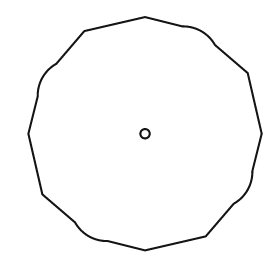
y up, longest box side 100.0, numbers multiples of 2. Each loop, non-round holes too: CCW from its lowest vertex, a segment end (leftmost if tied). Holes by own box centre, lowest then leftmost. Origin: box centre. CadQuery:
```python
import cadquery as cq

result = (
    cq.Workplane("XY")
    .moveTo(0.0, -50.0)
    .lineTo(26.0, -44.0)
    .lineTo(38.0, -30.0)
    .threePointArc((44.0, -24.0), (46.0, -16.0))
    .lineTo(50.0, 0.0)
    .lineTo(44.0, 26.0)
    .lineTo(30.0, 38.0)
    .threePointArc((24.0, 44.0), (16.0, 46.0))
    .lineTo(0.0, 50.0)
    .lineTo(-26.0, 44.0)
    .lineTo(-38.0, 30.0)
    .threePointArc((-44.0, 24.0), (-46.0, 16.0))
    .lineTo(-50.0, 0.0)
    .lineTo(-44.0, -26.0)
    .lineTo(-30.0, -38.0)
    .threePointArc((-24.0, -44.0), (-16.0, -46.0))
    .close()
    .moveTo(0.0, 0.0)
    .circle(2.0)
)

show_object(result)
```